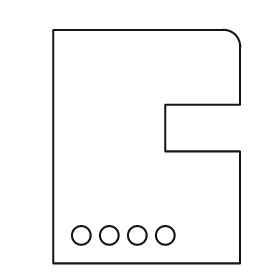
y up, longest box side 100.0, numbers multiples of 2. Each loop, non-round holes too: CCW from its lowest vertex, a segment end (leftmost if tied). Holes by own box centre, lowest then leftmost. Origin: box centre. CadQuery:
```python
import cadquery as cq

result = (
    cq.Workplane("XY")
    .moveTo(-40.0, -50.0)
    .lineTo(40.0, -50.0)
    .lineTo(40.0, -2.0)
    .lineTo(8.0, -2.0)
    .lineTo(8.0, 18.0)
    .lineTo(40.0, 18.0)
    .lineTo(40.0, 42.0)
    .threePointArc((38.0, 48.0), (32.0, 50.0))
    .lineTo(-40.0, 50.0)
    .close()
    .moveTo(-28.0, -38.0)
    .circle(4.0)
    .moveTo(-16.0, -38.0)
    .circle(4.0)
    .moveTo(-4.0, -38.0)
    .circle(4.0)
    .moveTo(8.0, -38.0)
    .circle(4.0)
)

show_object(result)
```